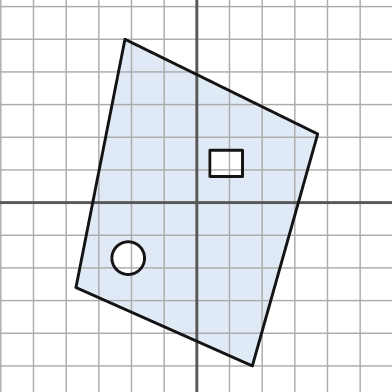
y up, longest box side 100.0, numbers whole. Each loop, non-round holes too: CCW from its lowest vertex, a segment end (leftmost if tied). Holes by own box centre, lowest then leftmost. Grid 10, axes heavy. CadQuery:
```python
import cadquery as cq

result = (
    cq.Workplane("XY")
    .moveTo(17.0, -50.0)
    .lineTo(37.0, 21.0)
    .lineTo(-22.0, 50.0)
    .lineTo(-37.0, -26.0)
    .close()
    .moveTo(-21.0, -17.0)
    .circle(5.0)
    .moveTo(4.0, 8.0)
    .lineTo(14.0, 8.0)
    .lineTo(14.0, 16.0)
    .lineTo(4.0, 16.0)
    .close()
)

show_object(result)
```